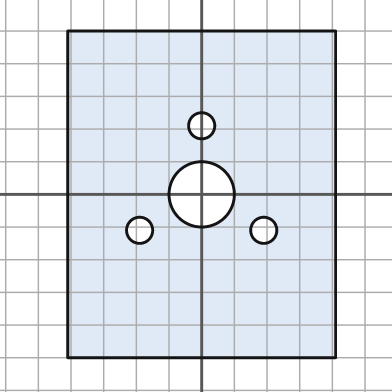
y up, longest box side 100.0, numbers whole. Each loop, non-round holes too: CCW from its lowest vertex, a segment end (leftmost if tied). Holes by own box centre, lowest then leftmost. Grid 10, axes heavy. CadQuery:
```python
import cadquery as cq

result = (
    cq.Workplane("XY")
    .moveTo(-41.0, -50.0)
    .lineTo(41.0, -50.0)
    .lineTo(41.0, 50.0)
    .lineTo(-41.0, 50.0)
    .close()
    .moveTo(-19.0, -11.0)
    .circle(4.0)
    .moveTo(19.0, -11.0)
    .circle(4.0)
    .moveTo(0.0, 0.0)
    .circle(10.0)
    .moveTo(0.0, 21.0)
    .circle(4.0)
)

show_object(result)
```